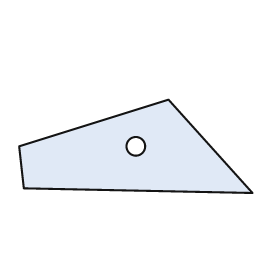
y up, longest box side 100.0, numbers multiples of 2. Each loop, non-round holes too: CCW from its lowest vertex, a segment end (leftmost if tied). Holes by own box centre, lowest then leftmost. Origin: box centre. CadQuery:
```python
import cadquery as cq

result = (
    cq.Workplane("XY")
    .moveTo(50.0, -20.0)
    .lineTo(14.0, 20.0)
    .lineTo(-50.0, 0.0)
    .lineTo(-48.0, -18.0)
    .close()
    .moveTo(0.0, 0.0)
    .circle(4.0)
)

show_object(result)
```